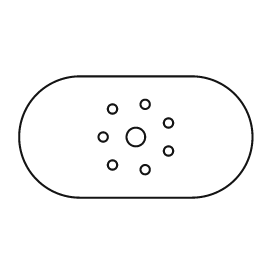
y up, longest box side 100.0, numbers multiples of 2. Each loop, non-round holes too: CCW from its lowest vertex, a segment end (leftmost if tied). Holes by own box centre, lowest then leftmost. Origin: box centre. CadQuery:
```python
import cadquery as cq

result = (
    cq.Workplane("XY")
    .moveTo(-24.0, -26.0)
    .lineTo(24.0, -26.0)
    .threePointArc((50.0, 0.0), (24.0, 26.0))
    .lineTo(-24.0, 26.0)
    .threePointArc((-50.0, 0.0), (-24.0, -26.0))
    .close()
    .moveTo(4.0, -14.0)
    .circle(2.0)
    .moveTo(-10.0, -12.0)
    .circle(2.0)
    .moveTo(14.0, -6.0)
    .circle(2.0)
    .moveTo(-14.0, 0.0)
    .circle(2.0)
    .moveTo(0.0, 0.0)
    .circle(4.0)
    .moveTo(14.0, 6.0)
    .circle(2.0)
    .moveTo(-10.0, 12.0)
    .circle(2.0)
    .moveTo(4.0, 14.0)
    .circle(2.0)
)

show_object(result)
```